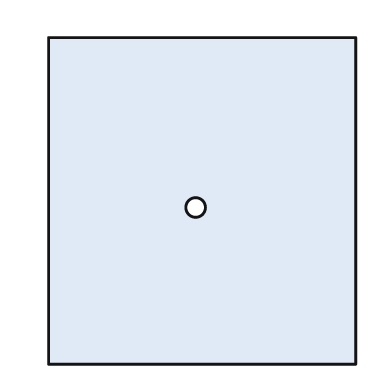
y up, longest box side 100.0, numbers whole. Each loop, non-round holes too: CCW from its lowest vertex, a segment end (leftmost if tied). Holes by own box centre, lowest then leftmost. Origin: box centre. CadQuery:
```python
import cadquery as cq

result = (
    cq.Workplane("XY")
    .moveTo(-47.0, -50.0)
    .lineTo(47.0, -50.0)
    .lineTo(47.0, 50.0)
    .lineTo(-47.0, 50.0)
    .close()
    .moveTo(-2.0, -2.0)
    .circle(3.0)
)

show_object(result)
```